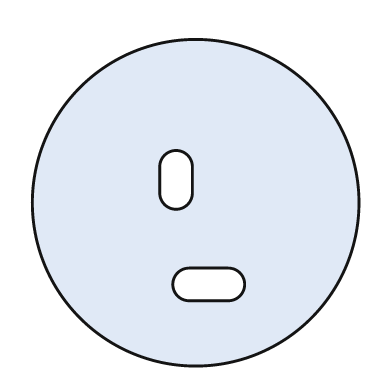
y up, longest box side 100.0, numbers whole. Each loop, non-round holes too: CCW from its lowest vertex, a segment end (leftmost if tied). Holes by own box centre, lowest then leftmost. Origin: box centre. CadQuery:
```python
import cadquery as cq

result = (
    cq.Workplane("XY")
    .moveTo(0.0, 0.0)
    .circle(50.0)
    .moveTo(-2.0, -30.0)
    .lineTo(10.0, -30.0)
    .threePointArc((15.0, -25.0), (10.0, -20.0))
    .lineTo(-2.0, -20.0)
    .threePointArc((-7.0, -25.0), (-2.0, -30.0))
    .close()
    .moveTo(-11.0, 3.0)
    .threePointArc((-6.0, -2.0), (-1.0, 3.0))
    .lineTo(-1.0, 11.0)
    .threePointArc((-6.0, 16.0), (-11.0, 11.0))
    .close()
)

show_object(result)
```